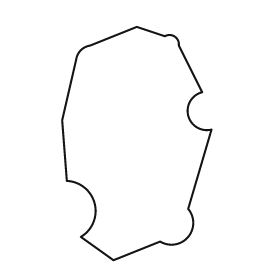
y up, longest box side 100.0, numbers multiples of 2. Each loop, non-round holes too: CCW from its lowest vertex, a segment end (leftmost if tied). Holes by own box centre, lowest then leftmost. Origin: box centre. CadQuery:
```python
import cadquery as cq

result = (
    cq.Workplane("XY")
    .moveTo(-10.0, -50.0)
    .lineTo(10.0, -42.0)
    .threePointArc((22.0, -40.0), (22.0, -28.0))
    .lineTo(32.0, 6.0)
    .threePointArc((22.0, 12.0), (28.0, 22.0))
    .lineTo(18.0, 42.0)
    .threePointArc((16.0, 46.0), (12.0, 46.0))
    .lineTo(0.0, 50.0)
    .lineTo(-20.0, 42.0)
    .threePointArc((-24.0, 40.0), (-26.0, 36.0))
    .lineTo(-32.0, 10.0)
    .lineTo(-30.0, -16.0)
    .threePointArc((-18.0, -26.0), (-24.0, -40.0))
    .close()
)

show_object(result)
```